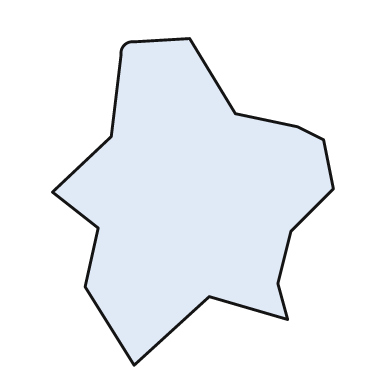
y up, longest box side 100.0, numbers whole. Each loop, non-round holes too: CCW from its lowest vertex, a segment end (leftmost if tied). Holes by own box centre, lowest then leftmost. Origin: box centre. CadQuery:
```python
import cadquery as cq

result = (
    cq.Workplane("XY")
    .moveTo(-18.0, -50.0)
    .lineTo(5.0, -29.0)
    .lineTo(29.0, -36.0)
    .lineTo(26.0, -25.0)
    .lineTo(30.0, -9.0)
    .lineTo(43.0, 4.0)
    .lineTo(40.0, 19.0)
    .lineTo(32.0, 23.0)
    .lineTo(13.0, 27.0)
    .lineTo(-1.0, 50.0)
    .lineTo(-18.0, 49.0)
    .threePointArc((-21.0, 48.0), (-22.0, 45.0))
    .lineTo(-25.0, 20.0)
    .lineTo(-43.0, 3.0)
    .lineTo(-29.0, -8.0)
    .lineTo(-33.0, -26.0)
    .close()
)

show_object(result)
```